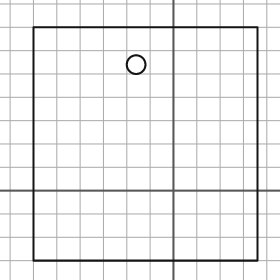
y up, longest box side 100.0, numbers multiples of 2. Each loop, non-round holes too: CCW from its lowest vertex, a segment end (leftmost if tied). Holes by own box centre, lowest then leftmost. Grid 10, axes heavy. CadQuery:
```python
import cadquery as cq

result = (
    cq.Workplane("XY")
    .moveTo(-60.0, -30.0)
    .lineTo(36.0, -30.0)
    .lineTo(36.0, 70.0)
    .lineTo(-60.0, 70.0)
    .close()
    .moveTo(-16.0, 54.0)
    .circle(4.0)
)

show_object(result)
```